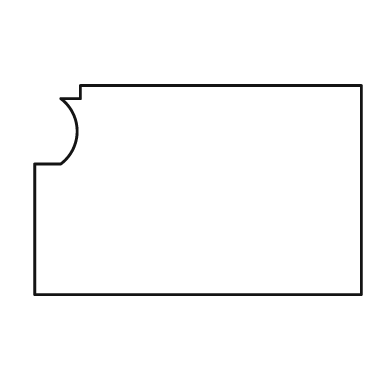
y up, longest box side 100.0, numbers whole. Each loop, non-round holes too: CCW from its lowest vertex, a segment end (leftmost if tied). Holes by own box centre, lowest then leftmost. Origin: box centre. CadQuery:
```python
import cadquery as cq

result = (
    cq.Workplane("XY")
    .moveTo(-50.0, -32.0)
    .lineTo(50.0, -32.0)
    .lineTo(50.0, 32.0)
    .lineTo(-36.0, 32.0)
    .lineTo(-36.0, 28.0)
    .lineTo(-42.0, 28.0)
    .threePointArc((-37.0, 18.0), (-42.0, 8.0))
    .lineTo(-50.0, 8.0)
    .close()
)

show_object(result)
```